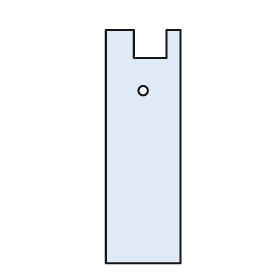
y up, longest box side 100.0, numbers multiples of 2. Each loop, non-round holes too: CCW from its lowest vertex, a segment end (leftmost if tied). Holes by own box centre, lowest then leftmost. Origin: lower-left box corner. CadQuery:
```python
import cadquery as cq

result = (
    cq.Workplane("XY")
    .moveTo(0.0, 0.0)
    .lineTo(32.0, 0.0)
    .lineTo(32.0, 100.0)
    .lineTo(26.0, 100.0)
    .lineTo(26.0, 88.0)
    .lineTo(12.0, 88.0)
    .lineTo(12.0, 100.0)
    .lineTo(0.0, 100.0)
    .close()
    .moveTo(16.0, 74.0)
    .circle(2.0)
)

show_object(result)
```